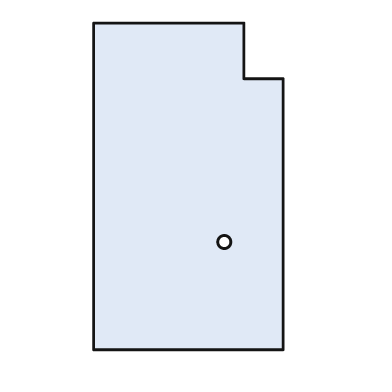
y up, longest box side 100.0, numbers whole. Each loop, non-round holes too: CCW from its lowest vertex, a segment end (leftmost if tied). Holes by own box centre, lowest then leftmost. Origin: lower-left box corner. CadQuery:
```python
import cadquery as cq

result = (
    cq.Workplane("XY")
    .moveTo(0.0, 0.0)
    .lineTo(58.0, 0.0)
    .lineTo(58.0, 83.0)
    .lineTo(46.0, 83.0)
    .lineTo(46.0, 100.0)
    .lineTo(0.0, 100.0)
    .close()
    .moveTo(40.0, 33.0)
    .circle(2.0)
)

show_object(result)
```